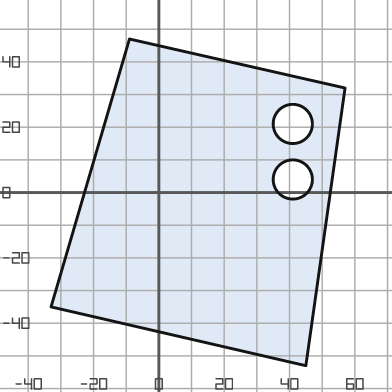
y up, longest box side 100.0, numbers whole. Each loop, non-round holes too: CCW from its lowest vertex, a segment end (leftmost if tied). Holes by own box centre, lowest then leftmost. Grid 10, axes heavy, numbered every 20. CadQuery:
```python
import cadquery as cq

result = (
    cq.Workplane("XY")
    .moveTo(45.0, -53.0)
    .lineTo(57.0, 32.0)
    .lineTo(-9.0, 47.0)
    .lineTo(-33.0, -35.0)
    .close()
    .moveTo(41.0, 4.0)
    .circle(6.0)
    .moveTo(41.0, 21.0)
    .circle(6.0)
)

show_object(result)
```